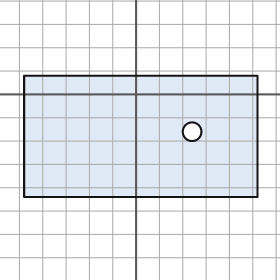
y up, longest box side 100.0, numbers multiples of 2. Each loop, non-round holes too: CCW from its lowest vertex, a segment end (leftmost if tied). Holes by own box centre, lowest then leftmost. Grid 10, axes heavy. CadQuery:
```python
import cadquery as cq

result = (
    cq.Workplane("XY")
    .moveTo(-48.0, -44.0)
    .lineTo(52.0, -44.0)
    .lineTo(52.0, 8.0)
    .lineTo(-48.0, 8.0)
    .close()
    .moveTo(24.0, -16.0)
    .circle(4.0)
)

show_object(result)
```